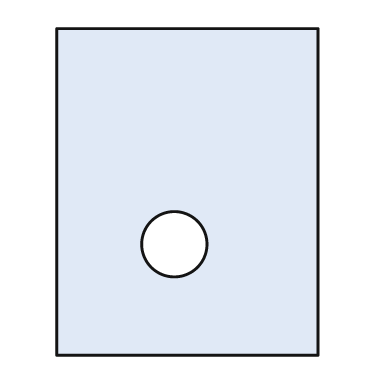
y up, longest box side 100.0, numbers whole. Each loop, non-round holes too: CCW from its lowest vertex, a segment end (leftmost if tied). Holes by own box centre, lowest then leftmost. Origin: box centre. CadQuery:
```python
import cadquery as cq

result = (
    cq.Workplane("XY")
    .moveTo(-40.0, -50.0)
    .lineTo(40.0, -50.0)
    .lineTo(40.0, 50.0)
    .lineTo(-40.0, 50.0)
    .close()
    .moveTo(-4.0, -16.0)
    .circle(10.0)
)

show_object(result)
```